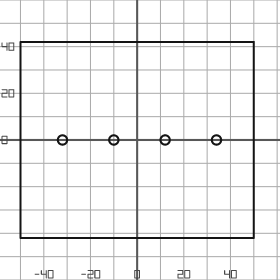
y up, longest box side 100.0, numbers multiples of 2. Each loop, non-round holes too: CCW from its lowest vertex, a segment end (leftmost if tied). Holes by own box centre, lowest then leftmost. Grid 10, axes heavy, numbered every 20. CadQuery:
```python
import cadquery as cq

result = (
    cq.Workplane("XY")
    .moveTo(-50.0, -42.0)
    .lineTo(50.0, -42.0)
    .lineTo(50.0, 42.0)
    .lineTo(-50.0, 42.0)
    .close()
    .moveTo(-32.0, 0.0)
    .circle(2.0)
    .moveTo(-10.0, 0.0)
    .circle(2.0)
    .moveTo(12.0, 0.0)
    .circle(2.0)
    .moveTo(34.0, 0.0)
    .circle(2.0)
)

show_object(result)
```